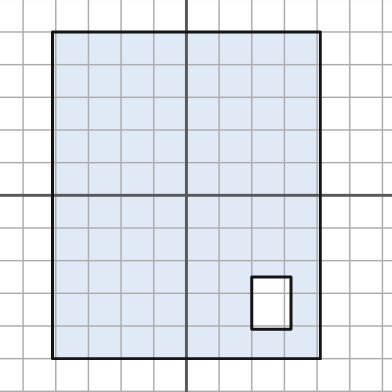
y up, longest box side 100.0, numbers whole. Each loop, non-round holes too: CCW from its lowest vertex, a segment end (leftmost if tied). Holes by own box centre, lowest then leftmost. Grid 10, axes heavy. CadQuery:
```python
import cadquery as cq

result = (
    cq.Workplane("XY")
    .moveTo(-41.0, -50.0)
    .lineTo(41.0, -50.0)
    .lineTo(41.0, 50.0)
    .lineTo(-41.0, 50.0)
    .close()
    .moveTo(20.0, -41.0)
    .lineTo(32.0, -41.0)
    .lineTo(32.0, -25.0)
    .lineTo(20.0, -25.0)
    .close()
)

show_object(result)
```